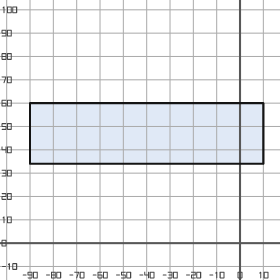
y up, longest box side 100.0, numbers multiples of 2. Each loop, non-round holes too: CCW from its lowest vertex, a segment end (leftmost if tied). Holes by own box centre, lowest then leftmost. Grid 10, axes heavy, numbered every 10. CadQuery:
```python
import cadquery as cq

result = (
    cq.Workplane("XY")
    .moveTo(-90.0, 34.0)
    .lineTo(10.0, 34.0)
    .lineTo(10.0, 60.0)
    .lineTo(-90.0, 60.0)
    .close()
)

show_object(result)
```